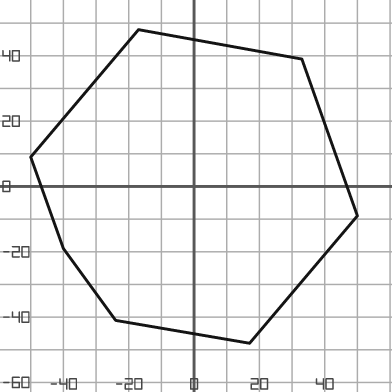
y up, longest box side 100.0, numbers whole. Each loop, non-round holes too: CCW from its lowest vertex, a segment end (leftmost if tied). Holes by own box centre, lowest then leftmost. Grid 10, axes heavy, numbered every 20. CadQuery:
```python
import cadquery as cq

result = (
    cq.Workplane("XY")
    .moveTo(17.0, -48.0)
    .lineTo(50.0, -9.0)
    .lineTo(33.0, 39.0)
    .lineTo(-17.0, 48.0)
    .lineTo(-50.0, 9.0)
    .lineTo(-40.0, -19.0)
    .lineTo(-24.0, -41.0)
    .close()
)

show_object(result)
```